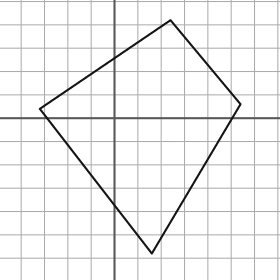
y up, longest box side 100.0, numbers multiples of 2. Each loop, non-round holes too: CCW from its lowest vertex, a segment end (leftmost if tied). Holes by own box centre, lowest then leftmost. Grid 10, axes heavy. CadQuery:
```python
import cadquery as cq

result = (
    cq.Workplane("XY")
    .moveTo(16.0, -58.0)
    .lineTo(54.0, 6.0)
    .lineTo(24.0, 42.0)
    .lineTo(-32.0, 4.0)
    .close()
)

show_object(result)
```